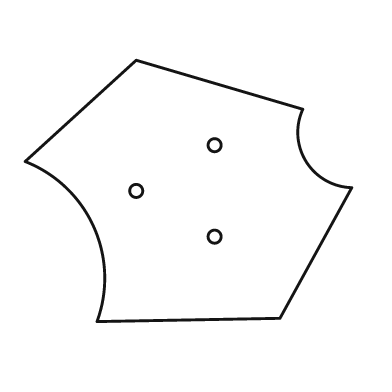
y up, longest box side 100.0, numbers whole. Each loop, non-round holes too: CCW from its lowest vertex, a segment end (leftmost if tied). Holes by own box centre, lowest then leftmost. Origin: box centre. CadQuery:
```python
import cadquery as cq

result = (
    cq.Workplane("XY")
    .moveTo(-28.0, -40.0)
    .lineTo(28.0, -39.0)
    .lineTo(50.0, 1.0)
    .threePointArc((36.0, 9.0), (35.0, 25.0))
    .lineTo(-16.0, 40.0)
    .lineTo(-50.0, 9.0)
    .threePointArc((-29.0, -11.0), (-28.0, -40.0))
    .close()
    .moveTo(8.0, -14.0)
    .circle(2.0)
    .moveTo(-16.0, 0.0)
    .circle(2.0)
    .moveTo(8.0, 14.0)
    .circle(2.0)
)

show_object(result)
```